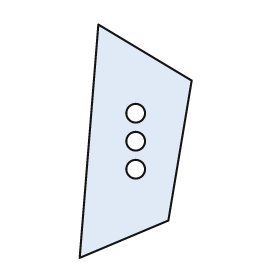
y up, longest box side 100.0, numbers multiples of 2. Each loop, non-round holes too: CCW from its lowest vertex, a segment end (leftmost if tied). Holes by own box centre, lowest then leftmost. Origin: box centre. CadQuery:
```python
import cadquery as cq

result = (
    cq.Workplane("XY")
    .moveTo(-24.0, -50.0)
    .lineTo(14.0, -34.0)
    .lineTo(24.0, 26.0)
    .lineTo(-16.0, 50.0)
    .close()
    .moveTo(0.0, -12.0)
    .circle(4.0)
    .moveTo(0.0, 0.0)
    .circle(4.0)
    .moveTo(0.0, 12.0)
    .circle(4.0)
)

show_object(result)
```